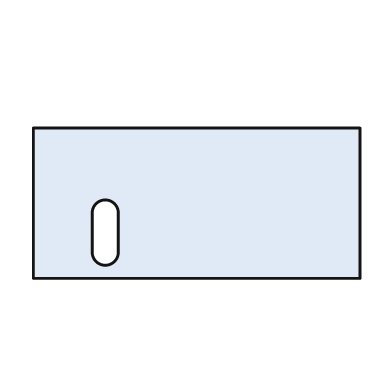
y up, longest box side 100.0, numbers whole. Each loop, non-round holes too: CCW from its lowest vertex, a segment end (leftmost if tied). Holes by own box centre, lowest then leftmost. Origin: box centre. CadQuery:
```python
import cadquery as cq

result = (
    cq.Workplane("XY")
    .moveTo(-50.0, -23.0)
    .lineTo(50.0, -23.0)
    .lineTo(50.0, 23.0)
    .lineTo(-50.0, 23.0)
    .close()
    .moveTo(-32.0, -15.0)
    .threePointArc((-28.0, -19.0), (-24.0, -15.0))
    .lineTo(-24.0, -3.0)
    .threePointArc((-28.0, 1.0), (-32.0, -3.0))
    .close()
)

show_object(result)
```